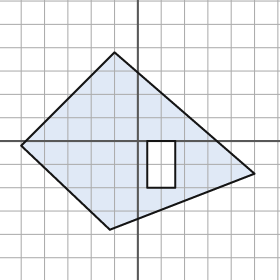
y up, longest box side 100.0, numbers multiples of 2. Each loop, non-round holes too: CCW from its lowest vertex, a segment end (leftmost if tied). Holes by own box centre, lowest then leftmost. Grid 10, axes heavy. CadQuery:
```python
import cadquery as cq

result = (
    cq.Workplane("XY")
    .moveTo(-12.0, -38.0)
    .lineTo(50.0, -14.0)
    .lineTo(-10.0, 38.0)
    .lineTo(-50.0, -2.0)
    .close()
    .moveTo(4.0, -20.0)
    .lineTo(16.0, -20.0)
    .lineTo(16.0, 0.0)
    .lineTo(4.0, 0.0)
    .close()
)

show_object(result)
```